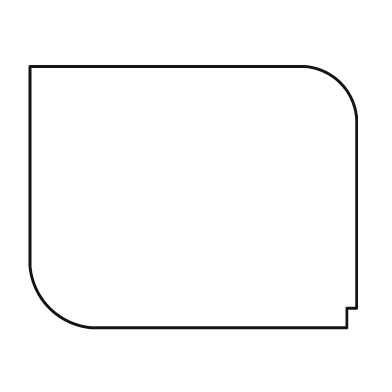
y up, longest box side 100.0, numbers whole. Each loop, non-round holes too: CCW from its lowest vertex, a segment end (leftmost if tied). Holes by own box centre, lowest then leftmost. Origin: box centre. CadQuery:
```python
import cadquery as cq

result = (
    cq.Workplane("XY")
    .moveTo(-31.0, -40.0)
    .lineTo(47.0, -40.0)
    .lineTo(47.0, -34.0)
    .lineTo(50.0, -34.0)
    .lineTo(50.0, 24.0)
    .threePointArc((45.0, 35.0), (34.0, 40.0))
    .lineTo(-50.0, 40.0)
    .lineTo(-50.0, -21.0)
    .threePointArc((-44.0, -34.0), (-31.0, -40.0))
    .close()
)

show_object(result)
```